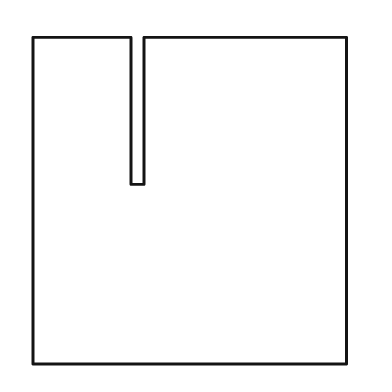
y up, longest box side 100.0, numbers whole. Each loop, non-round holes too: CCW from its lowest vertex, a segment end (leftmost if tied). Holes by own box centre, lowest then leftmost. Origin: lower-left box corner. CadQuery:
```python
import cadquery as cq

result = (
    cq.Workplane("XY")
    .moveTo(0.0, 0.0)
    .lineTo(96.0, 0.0)
    .lineTo(96.0, 100.0)
    .lineTo(34.0, 100.0)
    .lineTo(34.0, 55.0)
    .lineTo(30.0, 55.0)
    .lineTo(30.0, 100.0)
    .lineTo(0.0, 100.0)
    .close()
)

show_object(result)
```